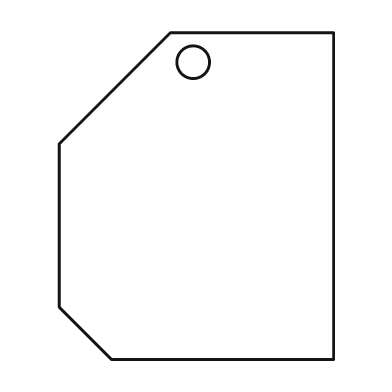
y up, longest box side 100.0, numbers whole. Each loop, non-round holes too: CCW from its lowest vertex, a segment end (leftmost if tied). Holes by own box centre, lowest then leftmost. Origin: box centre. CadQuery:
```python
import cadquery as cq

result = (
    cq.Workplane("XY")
    .moveTo(-26.0, -50.0)
    .lineTo(42.0, -50.0)
    .lineTo(42.0, 50.0)
    .lineTo(-8.0, 50.0)
    .lineTo(-42.0, 16.0)
    .lineTo(-42.0, -34.0)
    .close()
    .moveTo(-1.0, 41.0)
    .circle(5.0)
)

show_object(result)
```